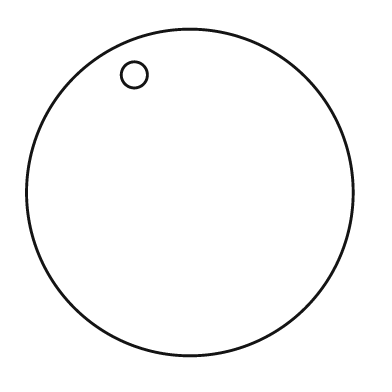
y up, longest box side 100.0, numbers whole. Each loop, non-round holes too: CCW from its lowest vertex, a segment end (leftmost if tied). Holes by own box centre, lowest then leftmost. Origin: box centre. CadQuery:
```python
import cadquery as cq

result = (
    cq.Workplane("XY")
    .moveTo(0.0, 0.0)
    .circle(50.0)
    .moveTo(-17.0, 36.0)
    .circle(4.0)
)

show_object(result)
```